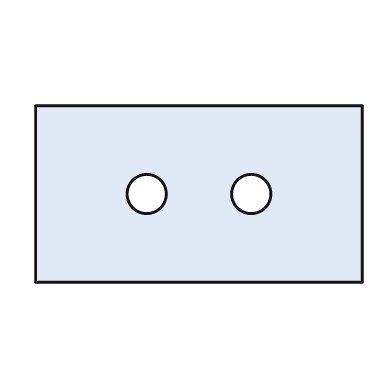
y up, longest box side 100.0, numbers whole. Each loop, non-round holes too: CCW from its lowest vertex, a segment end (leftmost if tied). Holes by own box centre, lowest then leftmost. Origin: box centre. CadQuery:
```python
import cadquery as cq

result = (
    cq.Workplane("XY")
    .moveTo(-50.0, -27.0)
    .lineTo(50.0, -27.0)
    .lineTo(50.0, 27.0)
    .lineTo(-50.0, 27.0)
    .close()
    .moveTo(-16.0, 0.0)
    .circle(6.0)
    .moveTo(16.0, 0.0)
    .circle(6.0)
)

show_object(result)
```